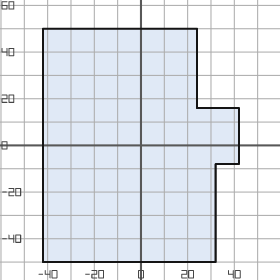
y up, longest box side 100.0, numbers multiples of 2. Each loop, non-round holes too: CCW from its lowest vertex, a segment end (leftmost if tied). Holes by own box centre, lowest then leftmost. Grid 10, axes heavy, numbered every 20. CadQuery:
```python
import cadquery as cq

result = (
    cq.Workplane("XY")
    .moveTo(-42.0, -50.0)
    .lineTo(32.0, -50.0)
    .lineTo(32.0, -8.0)
    .lineTo(42.0, -8.0)
    .lineTo(42.0, 16.0)
    .lineTo(24.0, 16.0)
    .lineTo(24.0, 50.0)
    .lineTo(-42.0, 50.0)
    .close()
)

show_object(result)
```